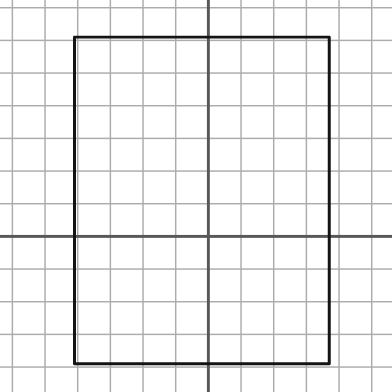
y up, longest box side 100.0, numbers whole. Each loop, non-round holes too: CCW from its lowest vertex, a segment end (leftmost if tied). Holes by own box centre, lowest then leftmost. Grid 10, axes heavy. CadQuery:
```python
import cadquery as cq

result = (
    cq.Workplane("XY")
    .moveTo(-41.0, -39.0)
    .lineTo(37.0, -39.0)
    .lineTo(37.0, 61.0)
    .lineTo(-41.0, 61.0)
    .close()
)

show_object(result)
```